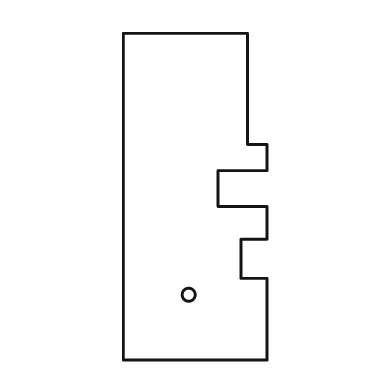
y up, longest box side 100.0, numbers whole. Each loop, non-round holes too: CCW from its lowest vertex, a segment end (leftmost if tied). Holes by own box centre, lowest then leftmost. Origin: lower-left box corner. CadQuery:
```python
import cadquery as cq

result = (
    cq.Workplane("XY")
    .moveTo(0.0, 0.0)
    .lineTo(44.0, 0.0)
    .lineTo(44.0, 25.0)
    .lineTo(36.0, 25.0)
    .lineTo(36.0, 37.0)
    .lineTo(44.0, 37.0)
    .lineTo(44.0, 47.0)
    .lineTo(29.0, 47.0)
    .lineTo(29.0, 58.0)
    .lineTo(44.0, 58.0)
    .lineTo(44.0, 66.0)
    .lineTo(38.0, 66.0)
    .lineTo(38.0, 100.0)
    .lineTo(0.0, 100.0)
    .close()
    .moveTo(20.0, 20.0)
    .circle(2.0)
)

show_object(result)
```